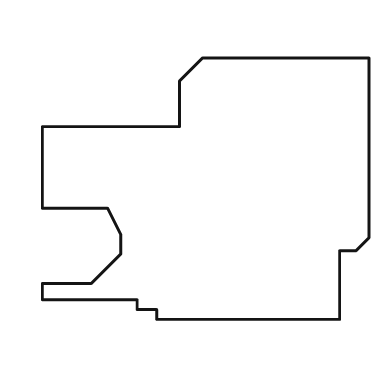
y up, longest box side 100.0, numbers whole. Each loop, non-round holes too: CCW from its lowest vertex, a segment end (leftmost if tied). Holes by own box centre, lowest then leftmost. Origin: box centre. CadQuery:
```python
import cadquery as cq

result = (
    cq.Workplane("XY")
    .moveTo(-15.0, -40.0)
    .lineTo(41.0, -40.0)
    .lineTo(41.0, -19.0)
    .lineTo(46.0, -19.0)
    .lineTo(50.0, -15.0)
    .lineTo(50.0, 40.0)
    .lineTo(-1.0, 40.0)
    .lineTo(-8.0, 33.0)
    .lineTo(-8.0, 19.0)
    .lineTo(-50.0, 19.0)
    .lineTo(-50.0, -6.0)
    .lineTo(-30.0, -6.0)
    .lineTo(-26.0, -14.0)
    .lineTo(-26.0, -20.0)
    .lineTo(-35.0, -29.0)
    .lineTo(-50.0, -29.0)
    .lineTo(-50.0, -34.0)
    .lineTo(-21.0, -34.0)
    .lineTo(-21.0, -37.0)
    .lineTo(-15.0, -37.0)
    .close()
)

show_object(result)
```